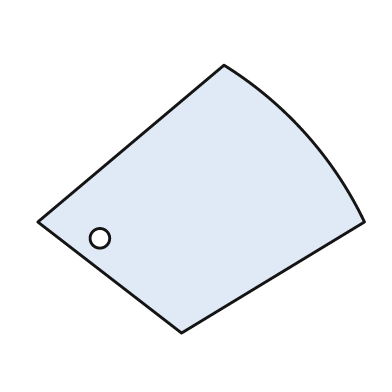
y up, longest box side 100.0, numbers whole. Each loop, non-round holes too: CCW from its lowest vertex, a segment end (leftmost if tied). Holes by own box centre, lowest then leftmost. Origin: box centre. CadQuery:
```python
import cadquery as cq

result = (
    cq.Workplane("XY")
    .moveTo(-6.0, -41.0)
    .lineTo(50.0, -7.0)
    .threePointArc((32.0, 20.0), (7.0, 41.0))
    .lineTo(-50.0, -7.0)
    .close()
    .moveTo(-31.0, -12.0)
    .circle(3.0)
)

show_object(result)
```